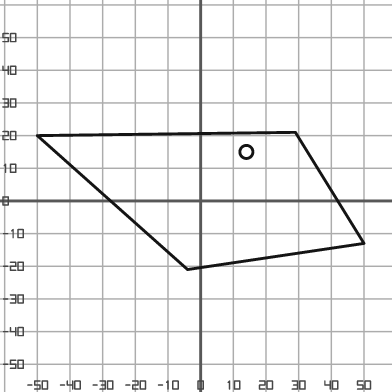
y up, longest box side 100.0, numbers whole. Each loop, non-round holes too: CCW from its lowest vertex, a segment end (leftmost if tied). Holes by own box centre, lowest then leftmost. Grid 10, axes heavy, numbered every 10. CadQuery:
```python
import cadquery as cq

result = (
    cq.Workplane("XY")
    .moveTo(-4.0, -21.0)
    .lineTo(50.0, -13.0)
    .lineTo(29.0, 21.0)
    .lineTo(-50.0, 20.0)
    .close()
    .moveTo(14.0, 15.0)
    .circle(2.0)
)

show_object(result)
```